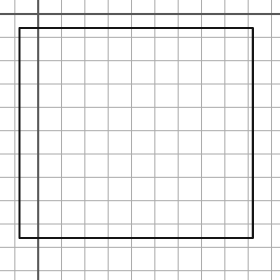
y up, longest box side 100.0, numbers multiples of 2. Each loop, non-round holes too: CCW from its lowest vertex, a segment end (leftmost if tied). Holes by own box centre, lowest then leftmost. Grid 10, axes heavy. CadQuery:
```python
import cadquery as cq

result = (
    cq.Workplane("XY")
    .moveTo(-8.0, -96.0)
    .lineTo(92.0, -96.0)
    .lineTo(92.0, -6.0)
    .lineTo(-8.0, -6.0)
    .close()
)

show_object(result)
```